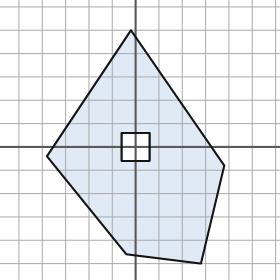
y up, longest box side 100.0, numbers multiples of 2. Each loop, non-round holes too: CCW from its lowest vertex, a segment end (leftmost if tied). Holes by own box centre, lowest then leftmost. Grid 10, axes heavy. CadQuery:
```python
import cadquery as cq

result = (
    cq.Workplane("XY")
    .moveTo(28.0, -50.0)
    .lineTo(38.0, -8.0)
    .lineTo(-2.0, 50.0)
    .lineTo(-38.0, -4.0)
    .lineTo(-4.0, -46.0)
    .close()
    .moveTo(-6.0, -6.0)
    .lineTo(6.0, -6.0)
    .lineTo(6.0, 6.0)
    .lineTo(-6.0, 6.0)
    .close()
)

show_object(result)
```